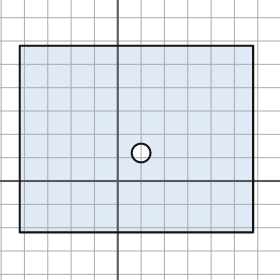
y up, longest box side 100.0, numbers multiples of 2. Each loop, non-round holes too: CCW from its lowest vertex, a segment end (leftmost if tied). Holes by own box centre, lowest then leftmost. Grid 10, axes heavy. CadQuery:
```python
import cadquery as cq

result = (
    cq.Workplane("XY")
    .moveTo(-42.0, -22.0)
    .lineTo(58.0, -22.0)
    .lineTo(58.0, 58.0)
    .lineTo(-42.0, 58.0)
    .close()
    .moveTo(10.0, 12.0)
    .circle(4.0)
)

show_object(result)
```